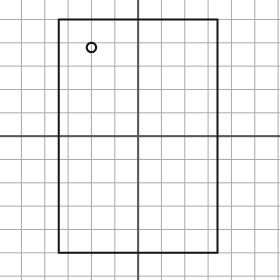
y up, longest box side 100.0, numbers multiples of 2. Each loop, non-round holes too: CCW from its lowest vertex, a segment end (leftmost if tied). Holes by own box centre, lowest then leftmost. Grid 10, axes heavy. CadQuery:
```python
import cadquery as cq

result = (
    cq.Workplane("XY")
    .moveTo(-34.0, -50.0)
    .lineTo(34.0, -50.0)
    .lineTo(34.0, 50.0)
    .lineTo(-34.0, 50.0)
    .close()
    .moveTo(-20.0, 38.0)
    .circle(2.0)
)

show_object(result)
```